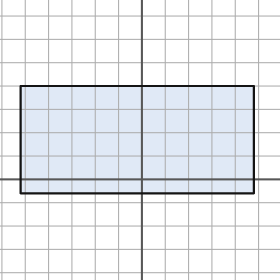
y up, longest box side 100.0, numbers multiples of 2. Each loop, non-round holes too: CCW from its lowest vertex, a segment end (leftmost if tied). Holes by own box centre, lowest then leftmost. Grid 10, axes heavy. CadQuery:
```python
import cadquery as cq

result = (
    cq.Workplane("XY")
    .moveTo(-52.0, -6.0)
    .lineTo(48.0, -6.0)
    .lineTo(48.0, 40.0)
    .lineTo(-52.0, 40.0)
    .close()
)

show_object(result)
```